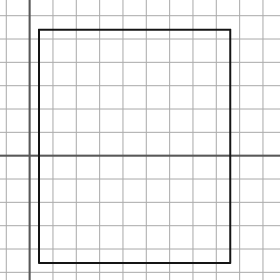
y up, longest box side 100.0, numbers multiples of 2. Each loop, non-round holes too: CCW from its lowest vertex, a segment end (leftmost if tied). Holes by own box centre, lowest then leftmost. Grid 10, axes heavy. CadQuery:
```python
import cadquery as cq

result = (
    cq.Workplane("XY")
    .moveTo(4.0, -46.0)
    .lineTo(86.0, -46.0)
    .lineTo(86.0, 54.0)
    .lineTo(4.0, 54.0)
    .close()
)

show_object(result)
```